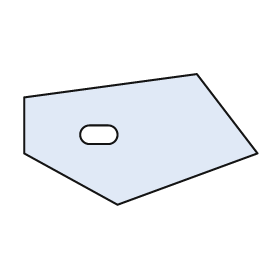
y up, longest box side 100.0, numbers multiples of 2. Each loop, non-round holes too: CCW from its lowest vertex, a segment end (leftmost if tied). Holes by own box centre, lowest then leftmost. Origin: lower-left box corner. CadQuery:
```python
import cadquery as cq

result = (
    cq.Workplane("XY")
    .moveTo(40.0, 0.0)
    .lineTo(100.0, 22.0)
    .lineTo(74.0, 56.0)
    .lineTo(0.0, 46.0)
    .lineTo(0.0, 22.0)
    .close()
    .moveTo(28.0, 26.0)
    .lineTo(36.0, 26.0)
    .threePointArc((40.0, 30.0), (36.0, 34.0))
    .lineTo(28.0, 34.0)
    .threePointArc((24.0, 30.0), (28.0, 26.0))
    .close()
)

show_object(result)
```